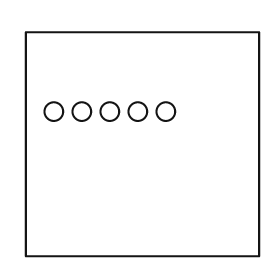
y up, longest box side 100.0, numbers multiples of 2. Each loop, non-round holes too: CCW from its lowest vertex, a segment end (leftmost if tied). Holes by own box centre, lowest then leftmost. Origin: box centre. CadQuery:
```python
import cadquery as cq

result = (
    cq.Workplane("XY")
    .moveTo(-50.0, -48.0)
    .lineTo(50.0, -48.0)
    .lineTo(50.0, 48.0)
    .lineTo(-50.0, 48.0)
    .close()
    .moveTo(-38.0, 14.0)
    .circle(4.0)
    .moveTo(-26.0, 14.0)
    .circle(4.0)
    .moveTo(-14.0, 14.0)
    .circle(4.0)
    .moveTo(-2.0, 14.0)
    .circle(4.0)
    .moveTo(10.0, 14.0)
    .circle(4.0)
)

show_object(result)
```